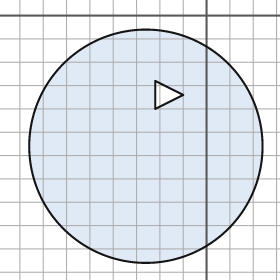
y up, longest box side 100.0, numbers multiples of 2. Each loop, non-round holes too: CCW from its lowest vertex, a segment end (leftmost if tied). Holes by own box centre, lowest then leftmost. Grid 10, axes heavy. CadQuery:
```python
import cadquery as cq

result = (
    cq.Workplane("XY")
    .moveTo(-26.0, -56.0)
    .circle(50.0)
    .moveTo(-22.0, -40.0)
    .lineTo(-10.0, -34.0)
    .lineTo(-22.0, -28.0)
    .close()
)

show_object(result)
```